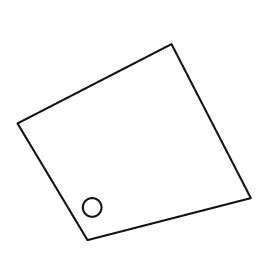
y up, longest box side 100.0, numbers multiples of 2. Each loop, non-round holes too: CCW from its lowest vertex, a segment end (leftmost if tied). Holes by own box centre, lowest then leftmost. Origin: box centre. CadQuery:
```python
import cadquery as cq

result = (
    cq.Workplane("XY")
    .moveTo(-20.0, -42.0)
    .lineTo(50.0, -24.0)
    .lineTo(16.0, 42.0)
    .lineTo(-50.0, 8.0)
    .close()
    .moveTo(-18.0, -28.0)
    .circle(4.0)
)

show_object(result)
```